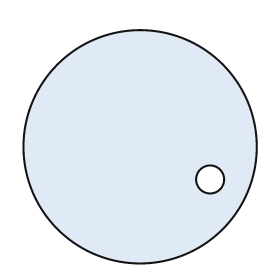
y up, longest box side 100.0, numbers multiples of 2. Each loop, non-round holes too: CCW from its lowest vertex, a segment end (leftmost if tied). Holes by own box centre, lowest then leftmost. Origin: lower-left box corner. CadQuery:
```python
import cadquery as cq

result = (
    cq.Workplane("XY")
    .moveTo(50.0, 50.0)
    .circle(50.0)
    .moveTo(80.0, 36.0)
    .circle(6.0)
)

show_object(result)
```